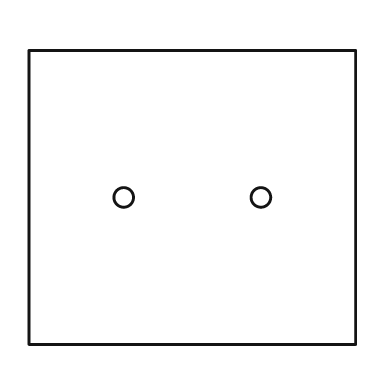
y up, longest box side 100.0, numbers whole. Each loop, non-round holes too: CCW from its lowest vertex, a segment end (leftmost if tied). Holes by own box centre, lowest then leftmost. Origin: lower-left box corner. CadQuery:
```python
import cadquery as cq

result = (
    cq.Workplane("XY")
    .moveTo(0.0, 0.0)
    .lineTo(100.0, 0.0)
    .lineTo(100.0, 90.0)
    .lineTo(0.0, 90.0)
    .close()
    .moveTo(29.0, 45.0)
    .circle(3.0)
    .moveTo(71.0, 45.0)
    .circle(3.0)
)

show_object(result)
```